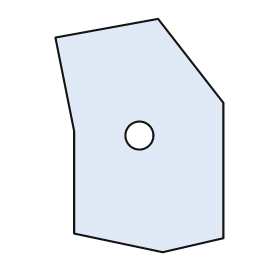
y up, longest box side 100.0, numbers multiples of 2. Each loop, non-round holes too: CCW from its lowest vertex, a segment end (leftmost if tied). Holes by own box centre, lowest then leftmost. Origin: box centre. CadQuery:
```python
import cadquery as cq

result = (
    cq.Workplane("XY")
    .moveTo(10.0, -50.0)
    .lineTo(36.0, -44.0)
    .lineTo(36.0, 14.0)
    .lineTo(8.0, 50.0)
    .lineTo(-36.0, 42.0)
    .lineTo(-28.0, 2.0)
    .lineTo(-28.0, -42.0)
    .close()
    .moveTo(0.0, 0.0)
    .circle(6.0)
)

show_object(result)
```